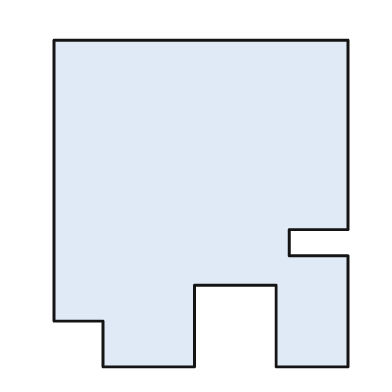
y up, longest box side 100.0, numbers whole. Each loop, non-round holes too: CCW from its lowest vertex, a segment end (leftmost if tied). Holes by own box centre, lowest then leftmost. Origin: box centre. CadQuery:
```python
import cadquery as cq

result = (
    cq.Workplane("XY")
    .moveTo(-30.0, -50.0)
    .lineTo(-2.0, -50.0)
    .lineTo(-2.0, -25.0)
    .lineTo(23.0, -25.0)
    .lineTo(23.0, -50.0)
    .lineTo(45.0, -50.0)
    .lineTo(45.0, -16.0)
    .lineTo(27.0, -16.0)
    .lineTo(27.0, -8.0)
    .lineTo(45.0, -8.0)
    .lineTo(45.0, 50.0)
    .lineTo(-45.0, 50.0)
    .lineTo(-45.0, -36.0)
    .lineTo(-30.0, -36.0)
    .close()
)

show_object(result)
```